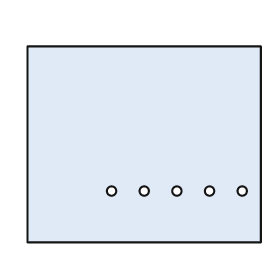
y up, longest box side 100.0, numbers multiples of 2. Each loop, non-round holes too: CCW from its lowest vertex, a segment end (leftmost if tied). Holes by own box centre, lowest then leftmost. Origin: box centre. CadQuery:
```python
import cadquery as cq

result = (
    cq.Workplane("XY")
    .moveTo(-50.0, -42.0)
    .lineTo(50.0, -42.0)
    .lineTo(50.0, 42.0)
    .lineTo(-50.0, 42.0)
    .close()
    .moveTo(-14.0, -20.0)
    .circle(2.0)
    .moveTo(0.0, -20.0)
    .circle(2.0)
    .moveTo(14.0, -20.0)
    .circle(2.0)
    .moveTo(28.0, -20.0)
    .circle(2.0)
    .moveTo(42.0, -20.0)
    .circle(2.0)
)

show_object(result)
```